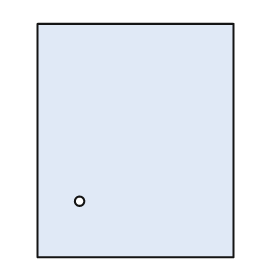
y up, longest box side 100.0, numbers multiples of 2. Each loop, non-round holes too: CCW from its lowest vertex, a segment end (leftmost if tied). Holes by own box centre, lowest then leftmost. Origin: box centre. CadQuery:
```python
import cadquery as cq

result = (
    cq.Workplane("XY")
    .moveTo(-42.0, -50.0)
    .lineTo(42.0, -50.0)
    .lineTo(42.0, 50.0)
    .lineTo(-42.0, 50.0)
    .close()
    .moveTo(-24.0, -26.0)
    .circle(2.0)
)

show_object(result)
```